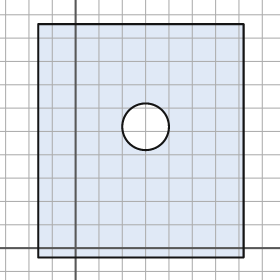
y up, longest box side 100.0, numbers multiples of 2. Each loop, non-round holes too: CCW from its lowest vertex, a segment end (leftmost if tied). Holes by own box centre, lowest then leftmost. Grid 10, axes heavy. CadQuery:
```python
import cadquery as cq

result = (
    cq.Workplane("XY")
    .moveTo(-16.0, -4.0)
    .lineTo(72.0, -4.0)
    .lineTo(72.0, 96.0)
    .lineTo(-16.0, 96.0)
    .close()
    .moveTo(30.0, 52.0)
    .circle(10.0)
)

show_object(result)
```